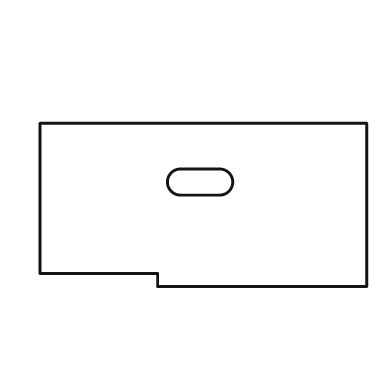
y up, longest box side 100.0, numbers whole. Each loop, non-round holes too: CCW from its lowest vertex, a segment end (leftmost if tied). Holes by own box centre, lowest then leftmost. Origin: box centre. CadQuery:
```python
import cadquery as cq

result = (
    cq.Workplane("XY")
    .moveTo(-14.0, -25.0)
    .lineTo(50.0, -25.0)
    .lineTo(50.0, 25.0)
    .lineTo(-50.0, 25.0)
    .lineTo(-50.0, -21.0)
    .lineTo(-14.0, -21.0)
    .close()
    .moveTo(-7.0, 3.0)
    .lineTo(5.0, 3.0)
    .threePointArc((9.0, 7.0), (5.0, 11.0))
    .lineTo(-7.0, 11.0)
    .threePointArc((-11.0, 7.0), (-7.0, 3.0))
    .close()
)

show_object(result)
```